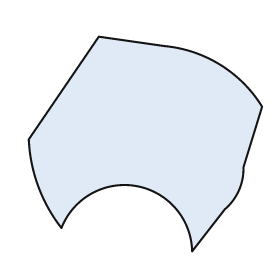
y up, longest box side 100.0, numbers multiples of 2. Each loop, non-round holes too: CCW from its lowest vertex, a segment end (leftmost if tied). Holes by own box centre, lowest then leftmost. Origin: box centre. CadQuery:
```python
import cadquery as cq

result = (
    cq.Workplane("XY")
    .moveTo(20.0, -46.0)
    .lineTo(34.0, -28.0)
    .threePointArc((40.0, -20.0), (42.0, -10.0))
    .lineTo(50.0, 16.0)
    .threePointArc((32.0, 34.0), (8.0, 42.0))
    .lineTo(-20.0, 46.0)
    .lineTo(-50.0, 2.0)
    .threePointArc((-46.0, -18.0), (-36.0, -36.0))
    .threePointArc((-4.0, -18.0), (20.0, -46.0))
    .close()
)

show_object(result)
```